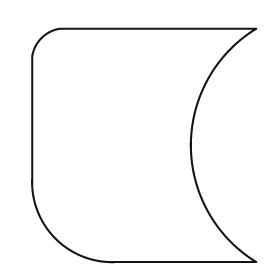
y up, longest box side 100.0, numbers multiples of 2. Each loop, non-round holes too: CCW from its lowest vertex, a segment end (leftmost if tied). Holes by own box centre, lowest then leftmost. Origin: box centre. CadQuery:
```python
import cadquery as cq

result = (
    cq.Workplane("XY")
    .moveTo(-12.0, -50.0)
    .lineTo(48.0, -50.0)
    .threePointArc((20.0, 0.0), (48.0, 50.0))
    .lineTo(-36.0, 50.0)
    .threePointArc((-44.0, 46.0), (-48.0, 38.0))
    .lineTo(-48.0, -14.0)
    .threePointArc((-38.0, -40.0), (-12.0, -50.0))
    .close()
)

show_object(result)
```